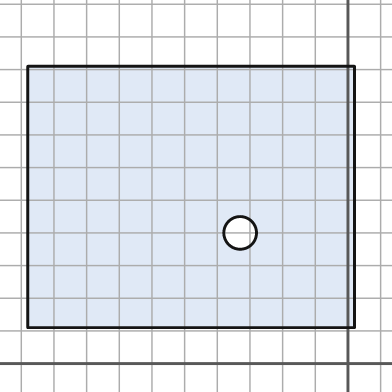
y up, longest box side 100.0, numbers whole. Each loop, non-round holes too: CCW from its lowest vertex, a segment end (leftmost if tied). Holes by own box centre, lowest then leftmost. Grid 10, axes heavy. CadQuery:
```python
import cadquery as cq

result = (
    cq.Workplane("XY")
    .moveTo(-98.0, 11.0)
    .lineTo(2.0, 11.0)
    .lineTo(2.0, 91.0)
    .lineTo(-98.0, 91.0)
    .close()
    .moveTo(-33.0, 40.0)
    .circle(5.0)
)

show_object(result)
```